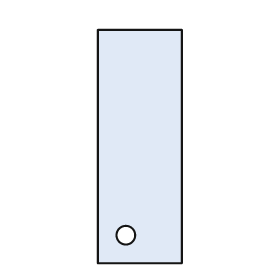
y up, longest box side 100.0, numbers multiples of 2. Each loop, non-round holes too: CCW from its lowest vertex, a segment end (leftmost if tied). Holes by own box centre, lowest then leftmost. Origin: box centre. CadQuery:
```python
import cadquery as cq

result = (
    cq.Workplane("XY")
    .moveTo(-18.0, -50.0)
    .lineTo(18.0, -50.0)
    .lineTo(18.0, 50.0)
    .lineTo(-18.0, 50.0)
    .close()
    .moveTo(-6.0, -38.0)
    .circle(4.0)
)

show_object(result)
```